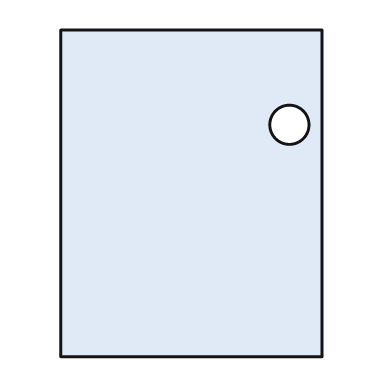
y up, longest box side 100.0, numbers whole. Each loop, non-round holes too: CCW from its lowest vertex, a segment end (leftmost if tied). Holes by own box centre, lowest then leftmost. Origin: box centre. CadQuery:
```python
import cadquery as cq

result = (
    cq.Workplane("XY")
    .moveTo(-40.0, -50.0)
    .lineTo(40.0, -50.0)
    .lineTo(40.0, 50.0)
    .lineTo(-40.0, 50.0)
    .close()
    .moveTo(30.0, 21.0)
    .circle(6.0)
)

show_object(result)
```